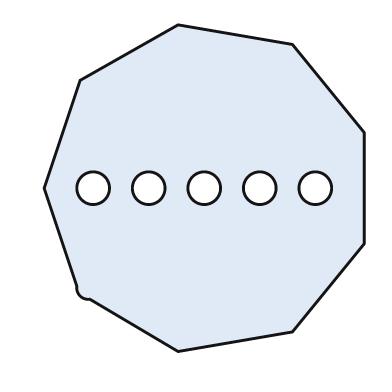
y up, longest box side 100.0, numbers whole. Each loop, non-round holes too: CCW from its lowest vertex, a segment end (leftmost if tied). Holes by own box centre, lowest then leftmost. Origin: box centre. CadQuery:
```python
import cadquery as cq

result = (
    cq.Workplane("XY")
    .moveTo(-8.0, -50.0)
    .lineTo(27.0, -44.0)
    .lineTo(49.0, -17.0)
    .lineTo(49.0, 17.0)
    .lineTo(27.0, 44.0)
    .lineTo(-8.0, 50.0)
    .lineTo(-38.0, 33.0)
    .lineTo(-49.0, 0.0)
    .lineTo(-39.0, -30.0)
    .threePointArc((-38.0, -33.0), (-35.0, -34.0))
    .close()
    .moveTo(-34.0, 0.0)
    .circle(5.0)
    .moveTo(-17.0, 0.0)
    .circle(5.0)
    .moveTo(0.0, 0.0)
    .circle(5.0)
    .moveTo(17.0, 0.0)
    .circle(5.0)
    .moveTo(34.0, 0.0)
    .circle(5.0)
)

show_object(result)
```